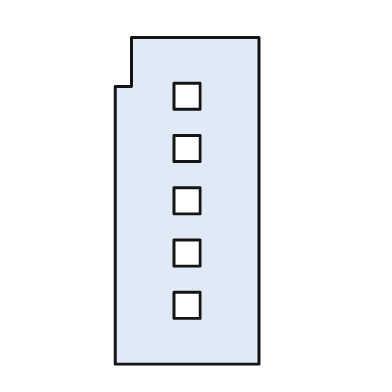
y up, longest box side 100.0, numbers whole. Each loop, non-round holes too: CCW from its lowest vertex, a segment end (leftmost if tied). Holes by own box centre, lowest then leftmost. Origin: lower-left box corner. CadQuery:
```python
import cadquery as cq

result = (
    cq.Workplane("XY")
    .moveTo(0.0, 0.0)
    .lineTo(44.0, 0.0)
    .lineTo(44.0, 100.0)
    .lineTo(5.0, 100.0)
    .lineTo(5.0, 85.0)
    .lineTo(0.0, 85.0)
    .close()
    .moveTo(18.0, 14.0)
    .lineTo(26.0, 14.0)
    .lineTo(26.0, 22.0)
    .lineTo(18.0, 22.0)
    .close()
    .moveTo(18.0, 30.0)
    .lineTo(26.0, 30.0)
    .lineTo(26.0, 38.0)
    .lineTo(18.0, 38.0)
    .close()
    .moveTo(18.0, 46.0)
    .lineTo(26.0, 46.0)
    .lineTo(26.0, 54.0)
    .lineTo(18.0, 54.0)
    .close()
    .moveTo(18.0, 62.0)
    .lineTo(26.0, 62.0)
    .lineTo(26.0, 70.0)
    .lineTo(18.0, 70.0)
    .close()
    .moveTo(18.0, 78.0)
    .lineTo(26.0, 78.0)
    .lineTo(26.0, 86.0)
    .lineTo(18.0, 86.0)
    .close()
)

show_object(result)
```